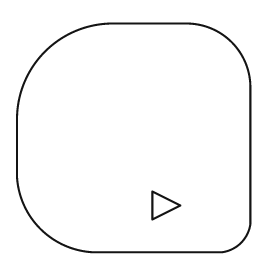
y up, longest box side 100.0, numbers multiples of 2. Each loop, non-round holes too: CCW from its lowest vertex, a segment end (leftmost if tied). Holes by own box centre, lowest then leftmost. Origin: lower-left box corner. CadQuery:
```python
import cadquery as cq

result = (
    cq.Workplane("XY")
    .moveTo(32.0, 0.0)
    .lineTo(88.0, 0.0)
    .threePointArc((96.0, 4.0), (100.0, 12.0))
    .lineTo(100.0, 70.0)
    .threePointArc((92.0, 90.0), (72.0, 98.0))
    .lineTo(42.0, 98.0)
    .threePointArc((12.0, 86.0), (0.0, 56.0))
    .lineTo(0.0, 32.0)
    .threePointArc((10.0, 10.0), (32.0, 0.0))
    .close()
    .moveTo(58.0, 14.0)
    .lineTo(70.0, 20.0)
    .lineTo(58.0, 26.0)
    .close()
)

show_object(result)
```